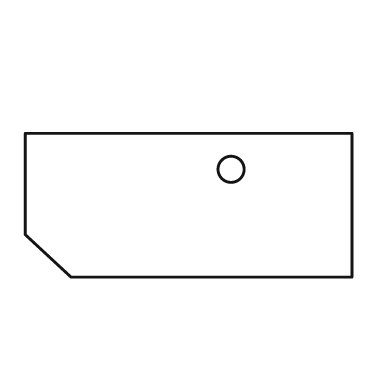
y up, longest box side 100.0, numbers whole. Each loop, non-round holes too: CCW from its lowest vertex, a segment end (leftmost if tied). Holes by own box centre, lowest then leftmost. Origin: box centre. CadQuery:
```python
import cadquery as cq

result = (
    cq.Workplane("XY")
    .moveTo(-36.0, -22.0)
    .lineTo(50.0, -22.0)
    .lineTo(50.0, 22.0)
    .lineTo(-50.0, 22.0)
    .lineTo(-50.0, -9.0)
    .close()
    .moveTo(13.0, 11.0)
    .circle(4.0)
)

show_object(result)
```